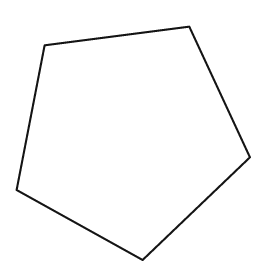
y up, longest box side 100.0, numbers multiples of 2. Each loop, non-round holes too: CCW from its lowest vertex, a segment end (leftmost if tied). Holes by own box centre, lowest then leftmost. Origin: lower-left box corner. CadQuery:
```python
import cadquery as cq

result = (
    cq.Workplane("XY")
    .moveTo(54.0, 0.0)
    .lineTo(100.0, 44.0)
    .lineTo(74.0, 100.0)
    .lineTo(12.0, 92.0)
    .lineTo(0.0, 30.0)
    .close()
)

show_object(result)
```